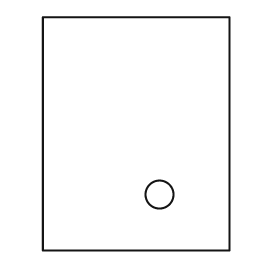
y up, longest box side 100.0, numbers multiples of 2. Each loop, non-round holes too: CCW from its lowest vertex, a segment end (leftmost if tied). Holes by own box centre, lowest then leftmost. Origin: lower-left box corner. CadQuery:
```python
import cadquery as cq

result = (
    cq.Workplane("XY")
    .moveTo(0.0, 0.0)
    .lineTo(80.0, 0.0)
    .lineTo(80.0, 100.0)
    .lineTo(0.0, 100.0)
    .close()
    .moveTo(50.0, 24.0)
    .circle(6.0)
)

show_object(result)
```